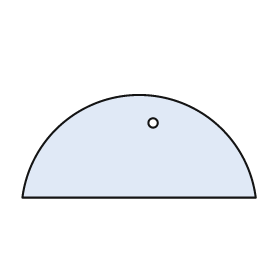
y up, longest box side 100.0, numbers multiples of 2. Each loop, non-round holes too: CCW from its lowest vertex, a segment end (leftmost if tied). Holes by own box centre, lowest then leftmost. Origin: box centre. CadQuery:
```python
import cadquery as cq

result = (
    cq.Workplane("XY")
    .moveTo(-50.0, -22.0)
    .lineTo(50.0, -22.0)
    .threePointArc((0.0, 22.0), (-50.0, -22.0))
    .close()
    .moveTo(6.0, 10.0)
    .circle(2.0)
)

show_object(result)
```